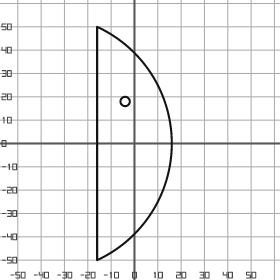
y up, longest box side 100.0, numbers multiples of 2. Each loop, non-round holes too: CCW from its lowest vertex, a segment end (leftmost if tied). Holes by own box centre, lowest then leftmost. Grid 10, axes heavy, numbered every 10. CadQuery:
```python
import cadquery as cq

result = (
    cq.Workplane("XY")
    .moveTo(-16.0, -50.0)
    .threePointArc((16.0, 0.0), (-16.0, 50.0))
    .close()
    .moveTo(-4.0, 18.0)
    .circle(2.0)
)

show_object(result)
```